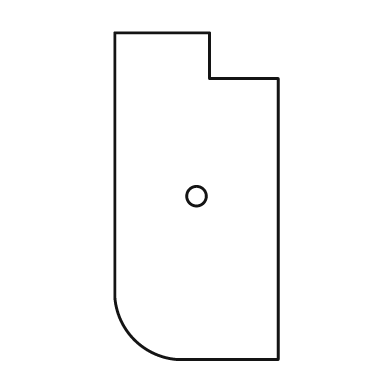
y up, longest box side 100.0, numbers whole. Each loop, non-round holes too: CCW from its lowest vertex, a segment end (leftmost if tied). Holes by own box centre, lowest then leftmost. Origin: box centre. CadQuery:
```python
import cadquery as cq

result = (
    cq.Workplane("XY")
    .moveTo(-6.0, -50.0)
    .lineTo(25.0, -50.0)
    .lineTo(25.0, 36.0)
    .lineTo(4.0, 36.0)
    .lineTo(4.0, 50.0)
    .lineTo(-25.0, 50.0)
    .lineTo(-25.0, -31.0)
    .threePointArc((-19.0, -44.0), (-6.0, -50.0))
    .close()
    .moveTo(0.0, 0.0)
    .circle(3.0)
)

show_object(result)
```